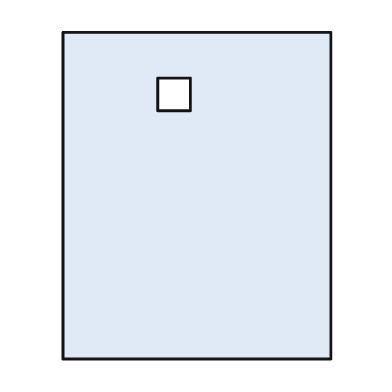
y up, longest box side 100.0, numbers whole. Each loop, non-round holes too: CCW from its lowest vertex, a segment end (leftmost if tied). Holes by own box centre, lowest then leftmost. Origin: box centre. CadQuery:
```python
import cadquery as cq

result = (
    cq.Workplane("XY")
    .moveTo(-41.0, -50.0)
    .lineTo(41.0, -50.0)
    .lineTo(41.0, 50.0)
    .lineTo(-41.0, 50.0)
    .close()
    .moveTo(-12.0, 26.0)
    .lineTo(-2.0, 26.0)
    .lineTo(-2.0, 36.0)
    .lineTo(-12.0, 36.0)
    .close()
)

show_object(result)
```